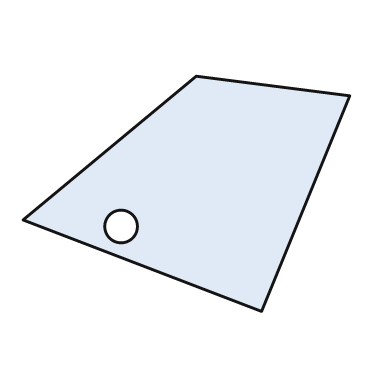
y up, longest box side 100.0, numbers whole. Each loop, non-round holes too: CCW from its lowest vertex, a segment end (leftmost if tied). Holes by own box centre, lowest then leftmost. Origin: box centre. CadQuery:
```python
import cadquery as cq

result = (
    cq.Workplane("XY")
    .moveTo(23.0, -36.0)
    .lineTo(50.0, 30.0)
    .lineTo(3.0, 36.0)
    .lineTo(-50.0, -8.0)
    .close()
    .moveTo(-20.0, -10.0)
    .circle(5.0)
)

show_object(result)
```